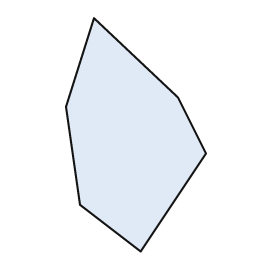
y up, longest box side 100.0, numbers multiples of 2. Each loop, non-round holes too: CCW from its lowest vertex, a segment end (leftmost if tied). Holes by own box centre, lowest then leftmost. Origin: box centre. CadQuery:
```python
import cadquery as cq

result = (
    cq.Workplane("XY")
    .moveTo(2.0, -50.0)
    .lineTo(30.0, -8.0)
    .lineTo(18.0, 16.0)
    .lineTo(-18.0, 50.0)
    .lineTo(-30.0, 12.0)
    .lineTo(-24.0, -30.0)
    .close()
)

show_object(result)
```